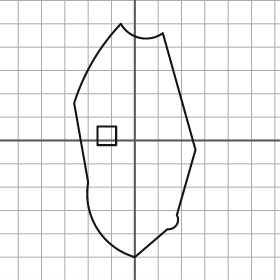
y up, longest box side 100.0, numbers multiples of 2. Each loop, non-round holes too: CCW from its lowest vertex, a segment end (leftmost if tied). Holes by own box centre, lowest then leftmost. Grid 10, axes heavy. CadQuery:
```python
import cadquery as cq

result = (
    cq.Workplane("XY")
    .moveTo(0.0, -50.0)
    .lineTo(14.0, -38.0)
    .threePointArc((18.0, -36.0), (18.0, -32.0))
    .lineTo(26.0, -4.0)
    .lineTo(12.0, 46.0)
    .threePointArc((2.0, 44.0), (-6.0, 50.0))
    .threePointArc((-18.0, 34.0), (-26.0, 16.0))
    .lineTo(-20.0, -18.0)
    .threePointArc((-16.0, -38.0), (0.0, -50.0))
    .close()
    .moveTo(-16.0, -2.0)
    .lineTo(-8.0, -2.0)
    .lineTo(-8.0, 6.0)
    .lineTo(-16.0, 6.0)
    .close()
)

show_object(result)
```